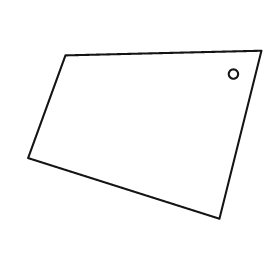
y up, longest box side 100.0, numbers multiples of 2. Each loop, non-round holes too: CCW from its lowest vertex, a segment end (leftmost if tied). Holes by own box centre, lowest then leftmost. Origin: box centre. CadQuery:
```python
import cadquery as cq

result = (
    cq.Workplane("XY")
    .moveTo(32.0, -36.0)
    .lineTo(50.0, 36.0)
    .lineTo(-34.0, 34.0)
    .lineTo(-50.0, -10.0)
    .close()
    .moveTo(38.0, 26.0)
    .circle(2.0)
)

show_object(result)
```